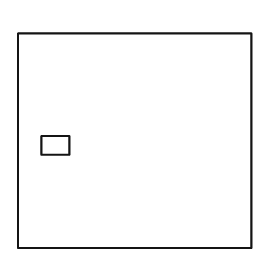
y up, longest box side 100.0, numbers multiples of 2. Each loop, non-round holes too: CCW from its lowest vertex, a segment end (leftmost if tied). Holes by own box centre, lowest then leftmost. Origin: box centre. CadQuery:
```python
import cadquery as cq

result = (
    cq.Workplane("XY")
    .moveTo(-50.0, -46.0)
    .lineTo(50.0, -46.0)
    .lineTo(50.0, 46.0)
    .lineTo(-50.0, 46.0)
    .close()
    .moveTo(-40.0, -6.0)
    .lineTo(-28.0, -6.0)
    .lineTo(-28.0, 2.0)
    .lineTo(-40.0, 2.0)
    .close()
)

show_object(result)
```